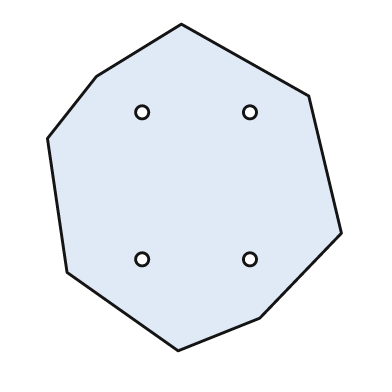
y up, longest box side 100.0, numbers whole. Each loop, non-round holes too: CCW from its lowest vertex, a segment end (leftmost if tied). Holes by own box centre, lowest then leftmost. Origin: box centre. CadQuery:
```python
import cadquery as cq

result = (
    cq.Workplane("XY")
    .moveTo(-5.0, -50.0)
    .lineTo(20.0, -40.0)
    .lineTo(45.0, -14.0)
    .lineTo(35.0, 28.0)
    .lineTo(-4.0, 50.0)
    .lineTo(-30.0, 34.0)
    .lineTo(-45.0, 15.0)
    .lineTo(-39.0, -26.0)
    .close()
    .moveTo(-16.0, -22.0)
    .circle(2.0)
    .moveTo(17.0, -22.0)
    .circle(2.0)
    .moveTo(-16.0, 23.0)
    .circle(2.0)
    .moveTo(17.0, 23.0)
    .circle(2.0)
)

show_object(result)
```